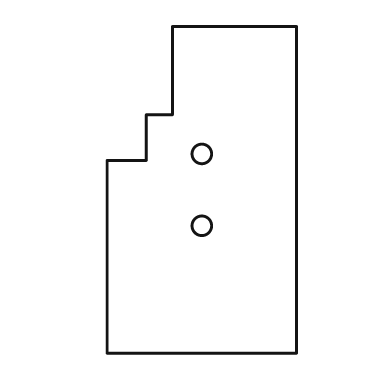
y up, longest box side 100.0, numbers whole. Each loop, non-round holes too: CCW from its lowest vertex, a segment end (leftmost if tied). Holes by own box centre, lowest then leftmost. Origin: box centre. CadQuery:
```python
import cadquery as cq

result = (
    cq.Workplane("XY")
    .moveTo(-29.0, -50.0)
    .lineTo(29.0, -50.0)
    .lineTo(29.0, 50.0)
    .lineTo(-9.0, 50.0)
    .lineTo(-9.0, 23.0)
    .lineTo(-17.0, 23.0)
    .lineTo(-17.0, 9.0)
    .lineTo(-29.0, 9.0)
    .close()
    .moveTo(0.0, -11.0)
    .circle(3.0)
    .moveTo(0.0, 11.0)
    .circle(3.0)
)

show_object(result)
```